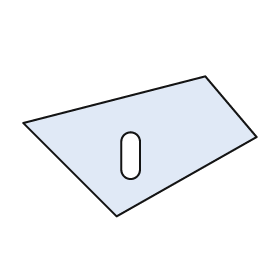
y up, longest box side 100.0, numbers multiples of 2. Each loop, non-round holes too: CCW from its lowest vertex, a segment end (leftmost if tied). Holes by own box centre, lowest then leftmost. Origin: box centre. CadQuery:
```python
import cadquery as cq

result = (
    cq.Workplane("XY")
    .moveTo(-10.0, -30.0)
    .lineTo(50.0, 4.0)
    .lineTo(28.0, 30.0)
    .lineTo(-50.0, 10.0)
    .close()
    .moveTo(-8.0, -10.0)
    .threePointArc((-4.0, -14.0), (0.0, -10.0))
    .lineTo(0.0, 2.0)
    .threePointArc((-4.0, 6.0), (-8.0, 2.0))
    .close()
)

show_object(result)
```